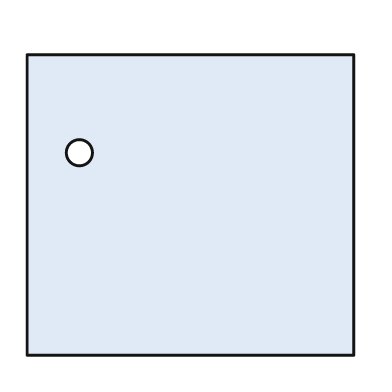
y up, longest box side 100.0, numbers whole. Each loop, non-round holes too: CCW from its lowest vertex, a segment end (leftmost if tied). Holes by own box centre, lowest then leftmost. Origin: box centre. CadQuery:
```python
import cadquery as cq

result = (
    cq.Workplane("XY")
    .moveTo(-50.0, -46.0)
    .lineTo(50.0, -46.0)
    .lineTo(50.0, 46.0)
    .lineTo(-50.0, 46.0)
    .close()
    .moveTo(-34.0, 16.0)
    .circle(4.0)
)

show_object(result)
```